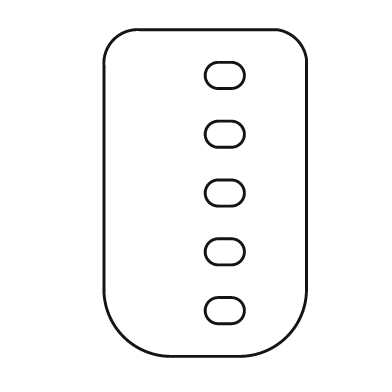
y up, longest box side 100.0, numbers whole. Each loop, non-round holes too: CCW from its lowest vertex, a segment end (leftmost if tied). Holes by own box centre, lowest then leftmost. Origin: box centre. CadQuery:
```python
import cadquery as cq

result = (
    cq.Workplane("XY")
    .moveTo(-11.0, -50.0)
    .lineTo(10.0, -50.0)
    .threePointArc((25.0, -44.0), (31.0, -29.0))
    .lineTo(31.0, 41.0)
    .threePointArc((28.0, 47.0), (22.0, 50.0))
    .lineTo(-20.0, 50.0)
    .threePointArc((-28.0, 47.0), (-31.0, 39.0))
    .lineTo(-31.0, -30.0)
    .threePointArc((-25.0, -44.0), (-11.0, -50.0))
    .close()
    .moveTo(4.0, -40.0)
    .lineTo(8.0, -40.0)
    .threePointArc((12.0, -36.0), (8.0, -32.0))
    .lineTo(4.0, -32.0)
    .threePointArc((0.0, -36.0), (4.0, -40.0))
    .close()
    .moveTo(4.0, -22.0)
    .lineTo(8.0, -22.0)
    .threePointArc((12.0, -18.0), (8.0, -14.0))
    .lineTo(4.0, -14.0)
    .threePointArc((0.0, -18.0), (4.0, -22.0))
    .close()
    .moveTo(4.0, -4.0)
    .lineTo(8.0, -4.0)
    .threePointArc((12.0, 0.0), (8.0, 4.0))
    .lineTo(4.0, 4.0)
    .threePointArc((0.0, 0.0), (4.0, -4.0))
    .close()
    .moveTo(4.0, 14.0)
    .lineTo(8.0, 14.0)
    .threePointArc((12.0, 18.0), (8.0, 22.0))
    .lineTo(4.0, 22.0)
    .threePointArc((0.0, 18.0), (4.0, 14.0))
    .close()
    .moveTo(4.0, 32.0)
    .lineTo(8.0, 32.0)
    .threePointArc((12.0, 36.0), (8.0, 40.0))
    .lineTo(4.0, 40.0)
    .threePointArc((0.0, 36.0), (4.0, 32.0))
    .close()
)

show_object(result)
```